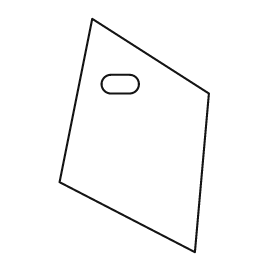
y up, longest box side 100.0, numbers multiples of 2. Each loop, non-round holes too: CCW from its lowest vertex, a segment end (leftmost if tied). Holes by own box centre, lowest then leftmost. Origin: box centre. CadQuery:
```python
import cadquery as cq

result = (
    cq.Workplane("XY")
    .moveTo(26.0, -50.0)
    .lineTo(32.0, 18.0)
    .lineTo(-18.0, 50.0)
    .lineTo(-32.0, -20.0)
    .close()
    .moveTo(-10.0, 18.0)
    .lineTo(-2.0, 18.0)
    .threePointArc((2.0, 22.0), (-2.0, 26.0))
    .lineTo(-10.0, 26.0)
    .threePointArc((-14.0, 22.0), (-10.0, 18.0))
    .close()
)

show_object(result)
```